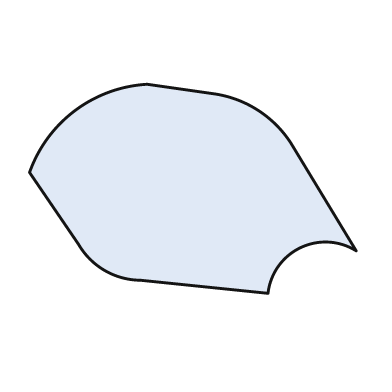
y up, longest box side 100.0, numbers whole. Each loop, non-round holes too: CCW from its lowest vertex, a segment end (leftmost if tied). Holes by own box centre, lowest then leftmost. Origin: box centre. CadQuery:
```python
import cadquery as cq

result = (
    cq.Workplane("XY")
    .moveTo(23.0, -32.0)
    .threePointArc((33.0, -18.0), (50.0, -19.0))
    .lineTo(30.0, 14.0)
    .threePointArc((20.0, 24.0), (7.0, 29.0))
    .lineTo(-14.0, 32.0)
    .threePointArc((-36.0, 24.0), (-50.0, 5.0))
    .lineTo(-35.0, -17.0)
    .threePointArc((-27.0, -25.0), (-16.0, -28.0))
    .close()
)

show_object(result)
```